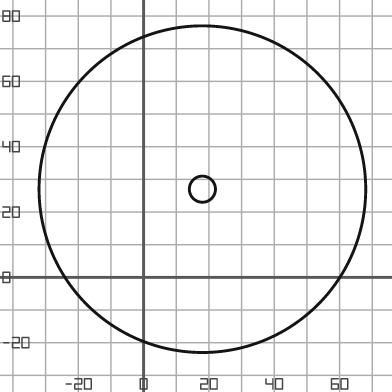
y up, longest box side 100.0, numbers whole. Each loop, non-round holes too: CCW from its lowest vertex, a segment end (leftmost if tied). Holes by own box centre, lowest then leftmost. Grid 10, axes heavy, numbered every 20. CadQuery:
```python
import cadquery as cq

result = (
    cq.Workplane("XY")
    .moveTo(18.0, 27.0)
    .circle(50.0)
    .moveTo(18.0, 27.0)
    .circle(4.0)
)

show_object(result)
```